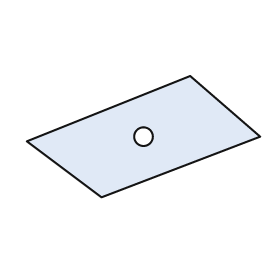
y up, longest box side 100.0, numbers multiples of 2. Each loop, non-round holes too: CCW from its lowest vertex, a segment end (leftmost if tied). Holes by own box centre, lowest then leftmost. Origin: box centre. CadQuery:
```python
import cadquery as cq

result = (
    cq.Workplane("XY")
    .moveTo(-18.0, -26.0)
    .lineTo(50.0, 0.0)
    .lineTo(20.0, 26.0)
    .lineTo(-50.0, -2.0)
    .close()
    .moveTo(0.0, 0.0)
    .circle(4.0)
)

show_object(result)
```